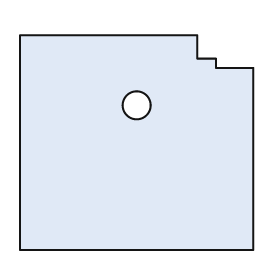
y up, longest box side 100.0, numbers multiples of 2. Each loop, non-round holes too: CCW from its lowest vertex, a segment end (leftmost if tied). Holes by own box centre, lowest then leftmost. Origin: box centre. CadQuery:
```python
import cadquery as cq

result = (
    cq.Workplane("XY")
    .moveTo(-50.0, -46.0)
    .lineTo(50.0, -46.0)
    .lineTo(50.0, 32.0)
    .lineTo(34.0, 32.0)
    .lineTo(34.0, 36.0)
    .lineTo(26.0, 36.0)
    .lineTo(26.0, 46.0)
    .lineTo(-50.0, 46.0)
    .close()
    .moveTo(0.0, 16.0)
    .circle(6.0)
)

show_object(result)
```